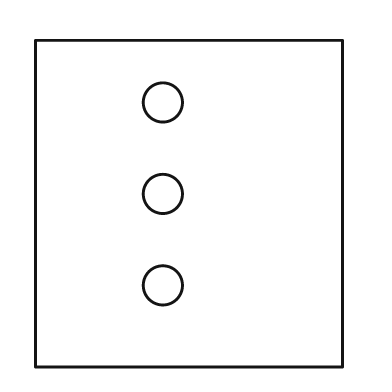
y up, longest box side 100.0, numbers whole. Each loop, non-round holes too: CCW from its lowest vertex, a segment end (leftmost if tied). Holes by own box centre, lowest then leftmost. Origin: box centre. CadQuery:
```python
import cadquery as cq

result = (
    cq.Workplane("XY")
    .moveTo(-47.0, -50.0)
    .lineTo(47.0, -50.0)
    .lineTo(47.0, 50.0)
    .lineTo(-47.0, 50.0)
    .close()
    .moveTo(-8.0, -25.0)
    .circle(6.0)
    .moveTo(-8.0, 3.0)
    .circle(6.0)
    .moveTo(-8.0, 31.0)
    .circle(6.0)
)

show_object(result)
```